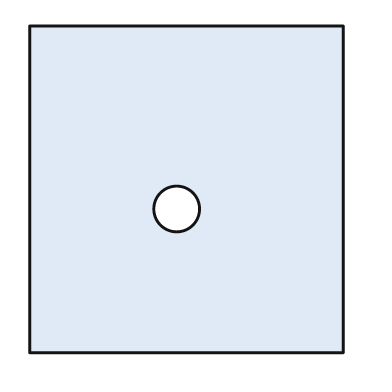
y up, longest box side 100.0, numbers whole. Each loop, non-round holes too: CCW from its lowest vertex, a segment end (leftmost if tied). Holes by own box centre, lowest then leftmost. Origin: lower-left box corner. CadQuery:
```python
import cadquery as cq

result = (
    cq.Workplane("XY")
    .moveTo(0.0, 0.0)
    .lineTo(96.0, 0.0)
    .lineTo(96.0, 100.0)
    .lineTo(0.0, 100.0)
    .close()
    .moveTo(45.0, 44.0)
    .circle(7.0)
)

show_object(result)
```